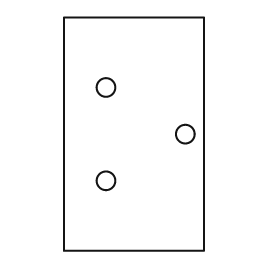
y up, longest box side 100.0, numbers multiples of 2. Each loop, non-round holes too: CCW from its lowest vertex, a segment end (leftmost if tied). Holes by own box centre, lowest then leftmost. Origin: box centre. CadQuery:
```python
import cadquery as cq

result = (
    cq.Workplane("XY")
    .moveTo(-30.0, -50.0)
    .lineTo(30.0, -50.0)
    .lineTo(30.0, 50.0)
    .lineTo(-30.0, 50.0)
    .close()
    .moveTo(-12.0, -20.0)
    .circle(4.0)
    .moveTo(22.0, 0.0)
    .circle(4.0)
    .moveTo(-12.0, 20.0)
    .circle(4.0)
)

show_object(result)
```